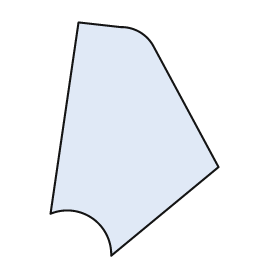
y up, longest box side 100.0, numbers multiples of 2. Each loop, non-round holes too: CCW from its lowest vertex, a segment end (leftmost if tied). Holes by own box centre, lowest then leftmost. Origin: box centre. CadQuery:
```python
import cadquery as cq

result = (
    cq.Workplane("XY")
    .moveTo(-10.0, -50.0)
    .lineTo(36.0, -12.0)
    .lineTo(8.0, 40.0)
    .threePointArc((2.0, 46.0), (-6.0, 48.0))
    .lineTo(-24.0, 50.0)
    .lineTo(-36.0, -32.0)
    .threePointArc((-18.0, -34.0), (-10.0, -50.0))
    .close()
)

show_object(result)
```